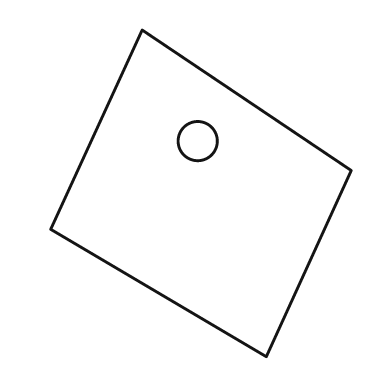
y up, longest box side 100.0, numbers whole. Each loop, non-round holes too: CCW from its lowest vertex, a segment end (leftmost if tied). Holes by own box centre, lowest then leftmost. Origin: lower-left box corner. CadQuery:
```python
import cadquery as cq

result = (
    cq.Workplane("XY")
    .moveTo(66.0, 0.0)
    .lineTo(92.0, 57.0)
    .lineTo(28.0, 100.0)
    .lineTo(0.0, 39.0)
    .close()
    .moveTo(45.0, 66.0)
    .circle(6.0)
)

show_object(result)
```